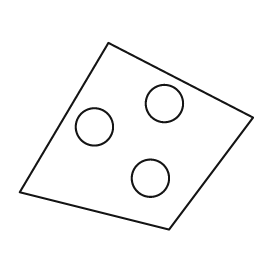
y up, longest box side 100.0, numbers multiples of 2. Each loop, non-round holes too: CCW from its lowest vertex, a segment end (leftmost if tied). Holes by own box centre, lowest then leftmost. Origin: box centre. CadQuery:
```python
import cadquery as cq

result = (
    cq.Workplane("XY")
    .moveTo(14.0, -40.0)
    .lineTo(50.0, 8.0)
    .lineTo(-12.0, 40.0)
    .lineTo(-50.0, -24.0)
    .close()
    .moveTo(6.0, -18.0)
    .circle(8.0)
    .moveTo(-18.0, 4.0)
    .circle(8.0)
    .moveTo(12.0, 14.0)
    .circle(8.0)
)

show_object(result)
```